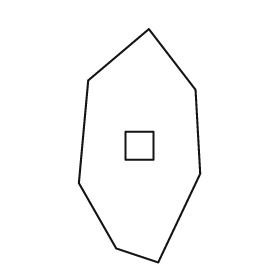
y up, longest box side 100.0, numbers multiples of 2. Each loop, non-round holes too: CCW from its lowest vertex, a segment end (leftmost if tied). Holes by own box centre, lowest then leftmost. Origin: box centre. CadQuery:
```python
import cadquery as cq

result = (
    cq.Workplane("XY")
    .moveTo(8.0, -50.0)
    .lineTo(26.0, -12.0)
    .lineTo(24.0, 24.0)
    .lineTo(4.0, 50.0)
    .lineTo(-22.0, 28.0)
    .lineTo(-26.0, -16.0)
    .lineTo(-10.0, -44.0)
    .close()
    .moveTo(-6.0, -6.0)
    .lineTo(6.0, -6.0)
    .lineTo(6.0, 6.0)
    .lineTo(-6.0, 6.0)
    .close()
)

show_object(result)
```